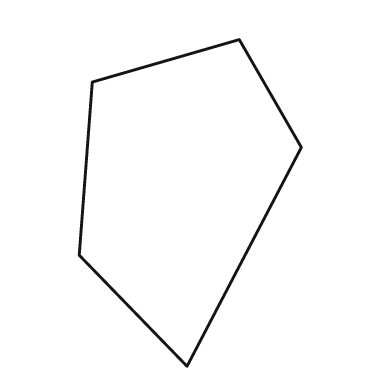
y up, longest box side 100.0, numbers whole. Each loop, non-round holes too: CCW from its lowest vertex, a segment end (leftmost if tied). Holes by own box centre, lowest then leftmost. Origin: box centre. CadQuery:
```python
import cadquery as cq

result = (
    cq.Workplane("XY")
    .moveTo(-1.0, -50.0)
    .lineTo(34.0, 17.0)
    .lineTo(15.0, 50.0)
    .lineTo(-30.0, 37.0)
    .lineTo(-34.0, -16.0)
    .close()
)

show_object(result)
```